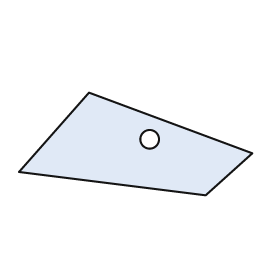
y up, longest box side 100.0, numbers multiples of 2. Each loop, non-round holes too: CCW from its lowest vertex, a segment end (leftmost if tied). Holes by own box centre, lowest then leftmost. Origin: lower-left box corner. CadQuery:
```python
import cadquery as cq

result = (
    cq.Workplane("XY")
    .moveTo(80.0, 0.0)
    .lineTo(100.0, 18.0)
    .lineTo(30.0, 44.0)
    .lineTo(0.0, 10.0)
    .close()
    .moveTo(56.0, 24.0)
    .circle(4.0)
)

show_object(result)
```